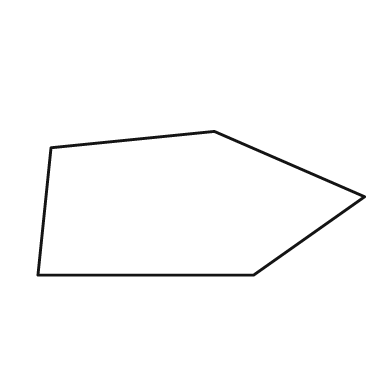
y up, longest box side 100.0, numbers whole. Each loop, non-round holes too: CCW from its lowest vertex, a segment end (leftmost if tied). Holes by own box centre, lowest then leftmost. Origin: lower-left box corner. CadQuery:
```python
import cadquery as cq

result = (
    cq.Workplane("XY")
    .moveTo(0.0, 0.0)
    .lineTo(66.0, 0.0)
    .lineTo(100.0, 24.0)
    .lineTo(54.0, 44.0)
    .lineTo(4.0, 39.0)
    .close()
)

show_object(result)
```